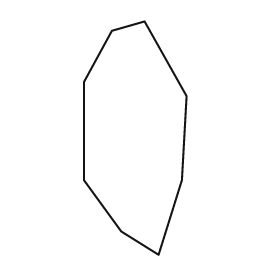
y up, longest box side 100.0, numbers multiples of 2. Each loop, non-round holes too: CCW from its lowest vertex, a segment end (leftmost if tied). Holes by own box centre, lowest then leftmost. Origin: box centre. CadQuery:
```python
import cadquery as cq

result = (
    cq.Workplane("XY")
    .moveTo(10.0, -50.0)
    .lineTo(20.0, -18.0)
    .lineTo(22.0, 18.0)
    .lineTo(4.0, 50.0)
    .lineTo(-10.0, 46.0)
    .lineTo(-22.0, 24.0)
    .lineTo(-22.0, -18.0)
    .lineTo(-6.0, -40.0)
    .close()
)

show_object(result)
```